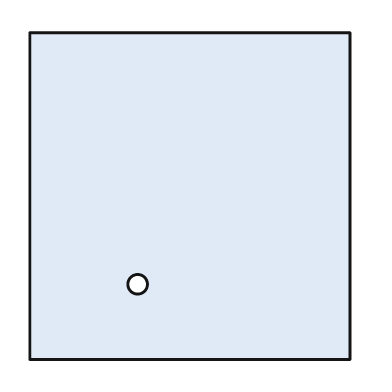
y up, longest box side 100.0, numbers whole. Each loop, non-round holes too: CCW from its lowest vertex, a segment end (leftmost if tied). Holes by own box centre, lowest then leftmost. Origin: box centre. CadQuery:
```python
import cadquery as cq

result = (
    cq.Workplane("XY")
    .moveTo(-49.0, -50.0)
    .lineTo(49.0, -50.0)
    .lineTo(49.0, 50.0)
    .lineTo(-49.0, 50.0)
    .close()
    .moveTo(-16.0, -27.0)
    .circle(3.0)
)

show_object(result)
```